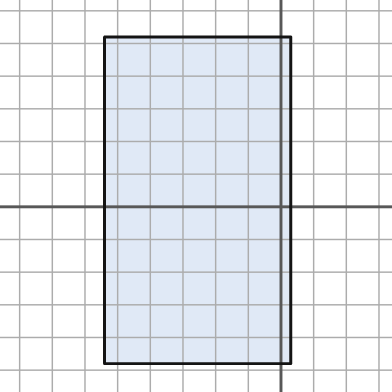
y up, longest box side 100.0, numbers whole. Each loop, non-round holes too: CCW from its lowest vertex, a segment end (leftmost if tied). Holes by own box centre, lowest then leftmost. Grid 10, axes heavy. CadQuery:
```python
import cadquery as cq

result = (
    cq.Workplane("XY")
    .moveTo(-54.0, -48.0)
    .lineTo(3.0, -48.0)
    .lineTo(3.0, 52.0)
    .lineTo(-54.0, 52.0)
    .close()
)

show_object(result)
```